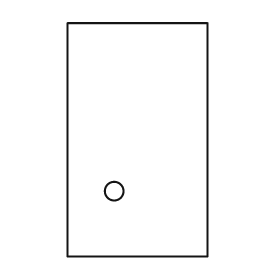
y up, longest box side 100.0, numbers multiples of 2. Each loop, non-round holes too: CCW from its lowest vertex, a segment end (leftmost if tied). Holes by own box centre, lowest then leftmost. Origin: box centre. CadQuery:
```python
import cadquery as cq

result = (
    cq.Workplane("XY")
    .moveTo(-30.0, -50.0)
    .lineTo(30.0, -50.0)
    .lineTo(30.0, 50.0)
    .lineTo(-30.0, 50.0)
    .close()
    .moveTo(-10.0, -22.0)
    .circle(4.0)
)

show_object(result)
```